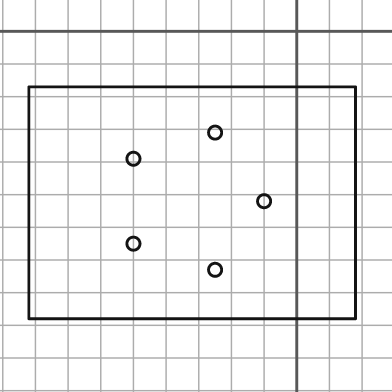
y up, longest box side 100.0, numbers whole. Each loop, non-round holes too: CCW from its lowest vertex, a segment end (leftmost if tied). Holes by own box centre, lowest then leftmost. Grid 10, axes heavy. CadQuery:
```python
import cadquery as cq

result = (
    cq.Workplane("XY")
    .moveTo(-82.0, -88.0)
    .lineTo(18.0, -88.0)
    .lineTo(18.0, -17.0)
    .lineTo(-82.0, -17.0)
    .close()
    .moveTo(-25.0, -73.0)
    .circle(2.0)
    .moveTo(-50.0, -65.0)
    .circle(2.0)
    .moveTo(-10.0, -52.0)
    .circle(2.0)
    .moveTo(-50.0, -39.0)
    .circle(2.0)
    .moveTo(-25.0, -31.0)
    .circle(2.0)
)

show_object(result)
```